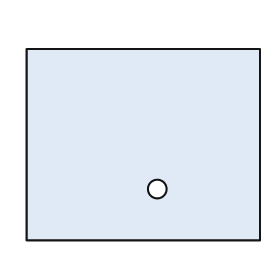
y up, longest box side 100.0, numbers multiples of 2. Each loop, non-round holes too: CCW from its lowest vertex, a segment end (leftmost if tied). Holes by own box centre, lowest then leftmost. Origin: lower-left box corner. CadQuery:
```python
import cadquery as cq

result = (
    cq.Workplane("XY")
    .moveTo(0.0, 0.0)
    .lineTo(100.0, 0.0)
    .lineTo(100.0, 82.0)
    .lineTo(0.0, 82.0)
    .close()
    .moveTo(56.0, 22.0)
    .circle(4.0)
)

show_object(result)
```